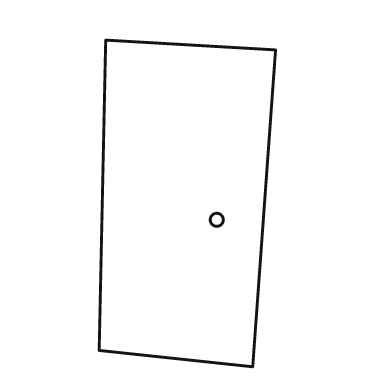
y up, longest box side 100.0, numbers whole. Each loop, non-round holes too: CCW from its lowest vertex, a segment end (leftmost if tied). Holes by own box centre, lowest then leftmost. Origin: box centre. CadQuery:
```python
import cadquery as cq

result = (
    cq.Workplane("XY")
    .moveTo(20.0, -50.0)
    .lineTo(27.0, 47.0)
    .lineTo(-25.0, 50.0)
    .lineTo(-27.0, -45.0)
    .close()
    .moveTo(9.0, -5.0)
    .circle(2.0)
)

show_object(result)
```